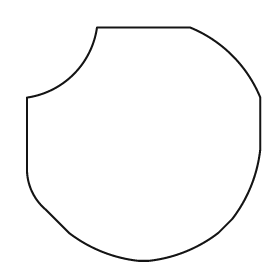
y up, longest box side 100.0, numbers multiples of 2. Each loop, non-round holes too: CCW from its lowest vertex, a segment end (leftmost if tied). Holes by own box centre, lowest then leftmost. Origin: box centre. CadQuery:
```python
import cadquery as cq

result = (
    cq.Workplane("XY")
    .moveTo(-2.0, -50.0)
    .lineTo(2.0, -50.0)
    .threePointArc((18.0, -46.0), (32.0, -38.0))
    .lineTo(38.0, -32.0)
    .threePointArc((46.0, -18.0), (50.0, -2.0))
    .lineTo(50.0, 20.0)
    .threePointArc((38.0, 38.0), (20.0, 50.0))
    .lineTo(-20.0, 50.0)
    .threePointArc((-30.0, 30.0), (-50.0, 20.0))
    .lineTo(-50.0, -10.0)
    .threePointArc((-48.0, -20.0), (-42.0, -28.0))
    .lineTo(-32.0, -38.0)
    .threePointArc((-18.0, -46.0), (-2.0, -50.0))
    .close()
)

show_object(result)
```